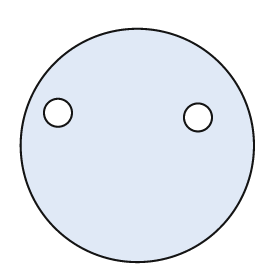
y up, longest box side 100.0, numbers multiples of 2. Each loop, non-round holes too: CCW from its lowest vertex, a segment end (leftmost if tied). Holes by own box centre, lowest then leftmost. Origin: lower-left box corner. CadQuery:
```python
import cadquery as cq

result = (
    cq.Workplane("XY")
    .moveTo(50.0, 50.0)
    .circle(50.0)
    .moveTo(76.0, 62.0)
    .circle(6.0)
    .moveTo(16.0, 64.0)
    .circle(6.0)
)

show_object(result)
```